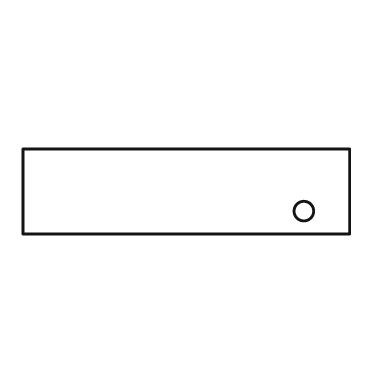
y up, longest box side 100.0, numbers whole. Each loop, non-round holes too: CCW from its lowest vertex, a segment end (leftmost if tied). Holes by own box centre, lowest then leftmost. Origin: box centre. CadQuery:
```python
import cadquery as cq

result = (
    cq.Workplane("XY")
    .moveTo(-50.0, -13.0)
    .lineTo(50.0, -13.0)
    .lineTo(50.0, 13.0)
    .lineTo(-50.0, 13.0)
    .close()
    .moveTo(36.0, -6.0)
    .circle(3.0)
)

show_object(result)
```